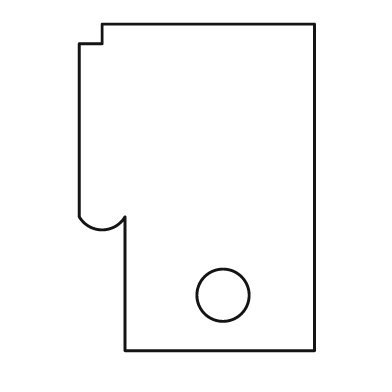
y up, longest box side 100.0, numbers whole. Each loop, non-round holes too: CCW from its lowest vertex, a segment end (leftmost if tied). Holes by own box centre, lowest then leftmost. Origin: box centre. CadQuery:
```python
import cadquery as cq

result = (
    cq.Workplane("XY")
    .moveTo(-22.0, -50.0)
    .lineTo(36.0, -50.0)
    .lineTo(36.0, 50.0)
    .lineTo(-29.0, 50.0)
    .lineTo(-29.0, 44.0)
    .lineTo(-36.0, 44.0)
    .lineTo(-36.0, -9.0)
    .threePointArc((-29.0, -13.0), (-22.0, -9.0))
    .close()
    .moveTo(8.0, -33.0)
    .circle(8.0)
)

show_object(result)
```